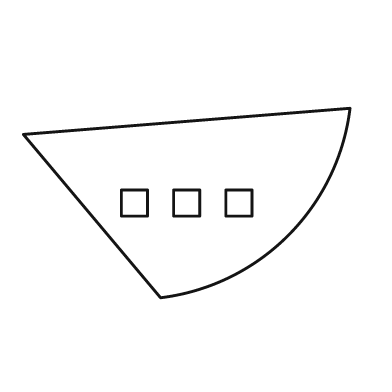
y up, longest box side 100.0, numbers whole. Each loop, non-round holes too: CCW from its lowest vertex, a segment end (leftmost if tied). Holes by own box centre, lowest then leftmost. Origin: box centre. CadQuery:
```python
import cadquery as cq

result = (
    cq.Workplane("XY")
    .moveTo(-8.0, -29.0)
    .threePointArc((31.0, -10.0), (50.0, 29.0))
    .lineTo(-50.0, 21.0)
    .close()
    .moveTo(-20.0, -4.0)
    .lineTo(-12.0, -4.0)
    .lineTo(-12.0, 4.0)
    .lineTo(-20.0, 4.0)
    .close()
    .moveTo(-4.0, -4.0)
    .lineTo(4.0, -4.0)
    .lineTo(4.0, 4.0)
    .lineTo(-4.0, 4.0)
    .close()
    .moveTo(12.0, -4.0)
    .lineTo(20.0, -4.0)
    .lineTo(20.0, 4.0)
    .lineTo(12.0, 4.0)
    .close()
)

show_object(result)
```